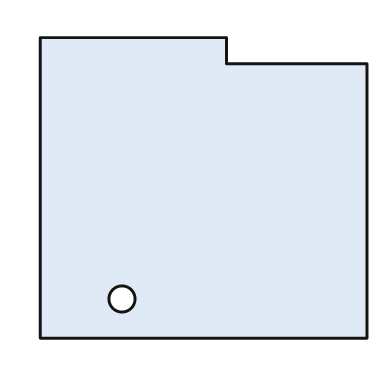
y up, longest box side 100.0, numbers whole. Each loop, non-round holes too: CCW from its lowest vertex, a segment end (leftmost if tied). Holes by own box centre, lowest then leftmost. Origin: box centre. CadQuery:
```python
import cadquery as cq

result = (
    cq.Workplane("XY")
    .moveTo(-50.0, -46.0)
    .lineTo(50.0, -46.0)
    .lineTo(50.0, 38.0)
    .lineTo(7.0, 38.0)
    .lineTo(7.0, 46.0)
    .lineTo(-50.0, 46.0)
    .close()
    .moveTo(-25.0, -34.0)
    .circle(4.0)
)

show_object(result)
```